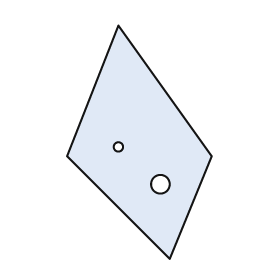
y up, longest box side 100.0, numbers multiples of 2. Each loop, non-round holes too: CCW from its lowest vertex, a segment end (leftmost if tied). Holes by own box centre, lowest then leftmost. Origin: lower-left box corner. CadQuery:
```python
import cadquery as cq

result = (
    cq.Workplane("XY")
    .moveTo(44.0, 0.0)
    .lineTo(62.0, 44.0)
    .lineTo(22.0, 100.0)
    .lineTo(0.0, 44.0)
    .close()
    .moveTo(40.0, 32.0)
    .circle(4.0)
    .moveTo(22.0, 48.0)
    .circle(2.0)
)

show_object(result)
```